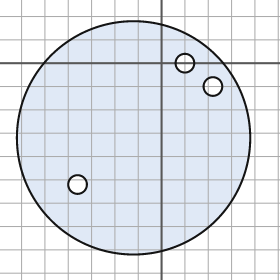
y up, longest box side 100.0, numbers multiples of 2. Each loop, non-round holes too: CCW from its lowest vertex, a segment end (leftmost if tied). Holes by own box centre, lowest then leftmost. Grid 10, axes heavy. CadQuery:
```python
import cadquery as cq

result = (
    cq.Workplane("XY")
    .moveTo(-12.0, -32.0)
    .circle(50.0)
    .moveTo(-36.0, -52.0)
    .circle(4.0)
    .moveTo(22.0, -10.0)
    .circle(4.0)
    .moveTo(10.0, 0.0)
    .circle(4.0)
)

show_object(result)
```